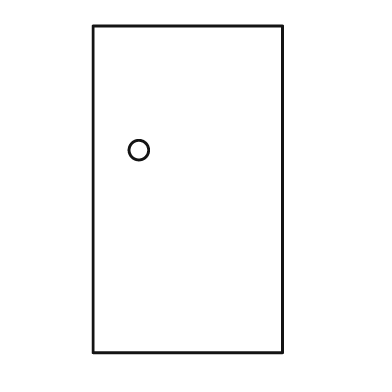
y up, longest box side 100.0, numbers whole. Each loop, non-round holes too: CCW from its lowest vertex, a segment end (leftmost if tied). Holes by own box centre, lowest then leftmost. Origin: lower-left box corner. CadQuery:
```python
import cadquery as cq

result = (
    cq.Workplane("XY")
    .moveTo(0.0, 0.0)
    .lineTo(58.0, 0.0)
    .lineTo(58.0, 100.0)
    .lineTo(0.0, 100.0)
    .close()
    .moveTo(14.0, 62.0)
    .circle(3.0)
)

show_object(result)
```